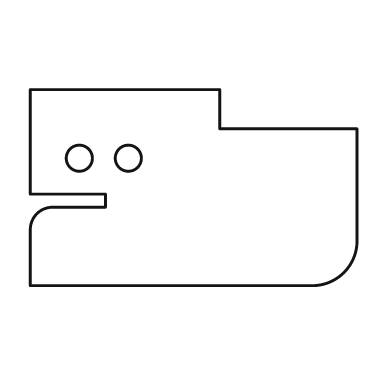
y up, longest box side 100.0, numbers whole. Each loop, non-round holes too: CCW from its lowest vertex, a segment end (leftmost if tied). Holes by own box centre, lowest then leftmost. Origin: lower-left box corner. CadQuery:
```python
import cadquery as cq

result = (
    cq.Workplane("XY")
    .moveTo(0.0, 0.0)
    .lineTo(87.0, 0.0)
    .threePointArc((96.0, 4.0), (100.0, 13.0))
    .lineTo(100.0, 48.0)
    .lineTo(58.0, 48.0)
    .lineTo(58.0, 60.0)
    .lineTo(0.0, 60.0)
    .lineTo(0.0, 28.0)
    .lineTo(23.0, 28.0)
    .lineTo(23.0, 24.0)
    .lineTo(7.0, 24.0)
    .threePointArc((2.0, 22.0), (0.0, 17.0))
    .close()
    .moveTo(15.0, 39.0)
    .circle(4.0)
    .moveTo(30.0, 39.0)
    .circle(4.0)
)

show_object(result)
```